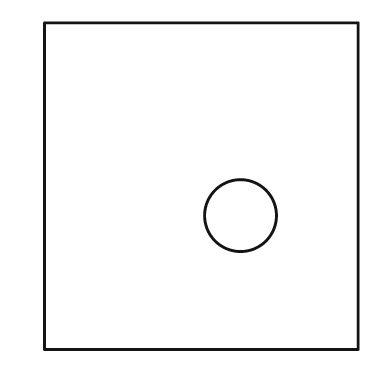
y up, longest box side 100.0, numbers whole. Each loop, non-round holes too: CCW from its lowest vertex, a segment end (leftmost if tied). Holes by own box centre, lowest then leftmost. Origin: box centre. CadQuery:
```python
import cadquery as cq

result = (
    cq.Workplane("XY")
    .moveTo(-48.0, -50.0)
    .lineTo(48.0, -50.0)
    .lineTo(48.0, 50.0)
    .lineTo(-48.0, 50.0)
    .close()
    .moveTo(12.0, -9.0)
    .circle(11.0)
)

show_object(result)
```